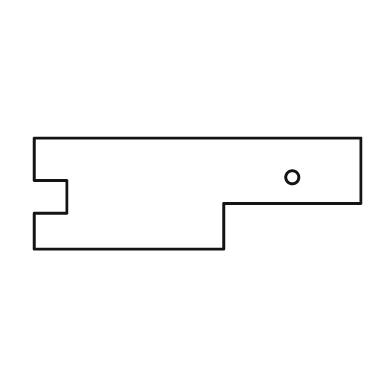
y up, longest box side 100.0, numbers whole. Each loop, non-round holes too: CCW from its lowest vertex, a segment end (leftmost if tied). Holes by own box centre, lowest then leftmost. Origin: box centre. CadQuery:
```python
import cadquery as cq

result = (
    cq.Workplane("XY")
    .moveTo(-50.0, -17.0)
    .lineTo(8.0, -17.0)
    .lineTo(8.0, -3.0)
    .lineTo(50.0, -3.0)
    .lineTo(50.0, 17.0)
    .lineTo(-50.0, 17.0)
    .lineTo(-50.0, 4.0)
    .lineTo(-40.0, 4.0)
    .lineTo(-40.0, -6.0)
    .lineTo(-50.0, -6.0)
    .close()
    .moveTo(29.0, 5.0)
    .circle(2.0)
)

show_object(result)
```